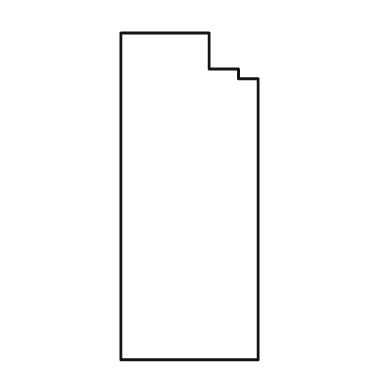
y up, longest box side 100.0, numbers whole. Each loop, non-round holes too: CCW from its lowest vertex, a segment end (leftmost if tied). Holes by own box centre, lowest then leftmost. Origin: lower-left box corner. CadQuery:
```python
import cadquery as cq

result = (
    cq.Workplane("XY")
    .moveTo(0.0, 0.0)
    .lineTo(42.0, 0.0)
    .lineTo(42.0, 86.0)
    .lineTo(36.0, 86.0)
    .lineTo(36.0, 89.0)
    .lineTo(27.0, 89.0)
    .lineTo(27.0, 100.0)
    .lineTo(0.0, 100.0)
    .close()
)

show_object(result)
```